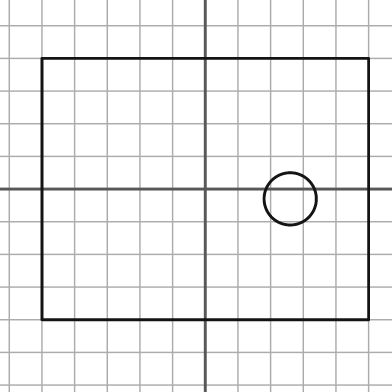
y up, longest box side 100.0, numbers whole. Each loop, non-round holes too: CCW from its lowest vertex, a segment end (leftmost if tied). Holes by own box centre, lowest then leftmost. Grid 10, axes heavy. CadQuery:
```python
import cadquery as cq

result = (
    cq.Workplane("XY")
    .moveTo(-50.0, -40.0)
    .lineTo(50.0, -40.0)
    .lineTo(50.0, 40.0)
    .lineTo(-50.0, 40.0)
    .close()
    .moveTo(26.0, -3.0)
    .circle(8.0)
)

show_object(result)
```